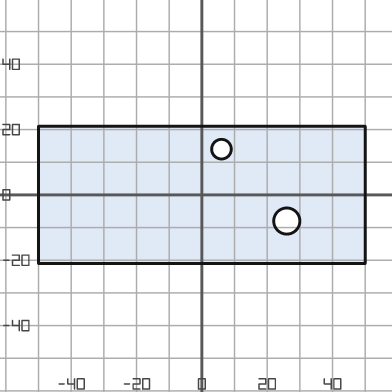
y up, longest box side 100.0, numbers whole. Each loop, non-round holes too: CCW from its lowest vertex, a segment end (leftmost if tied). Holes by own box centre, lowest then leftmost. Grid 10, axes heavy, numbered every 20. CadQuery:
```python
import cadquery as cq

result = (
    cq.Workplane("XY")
    .moveTo(-50.0, -21.0)
    .lineTo(50.0, -21.0)
    .lineTo(50.0, 21.0)
    .lineTo(-50.0, 21.0)
    .close()
    .moveTo(26.0, -8.0)
    .circle(4.0)
    .moveTo(6.0, 14.0)
    .circle(3.0)
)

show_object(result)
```